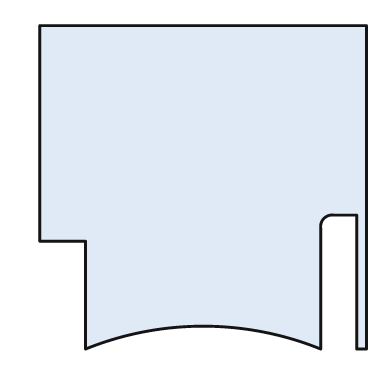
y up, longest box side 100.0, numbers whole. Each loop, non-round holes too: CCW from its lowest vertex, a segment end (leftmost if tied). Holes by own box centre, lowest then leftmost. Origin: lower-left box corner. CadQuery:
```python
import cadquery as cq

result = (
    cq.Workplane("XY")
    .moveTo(14.0, 0.0)
    .threePointArc((50.0, 7.0), (86.0, 0.0))
    .lineTo(86.0, 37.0)
    .threePointArc((87.0, 40.0), (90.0, 41.0))
    .lineTo(97.0, 41.0)
    .lineTo(97.0, 0.0)
    .lineTo(100.0, 0.0)
    .lineTo(100.0, 99.0)
    .lineTo(0.0, 99.0)
    .lineTo(0.0, 33.0)
    .lineTo(14.0, 33.0)
    .close()
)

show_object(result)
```